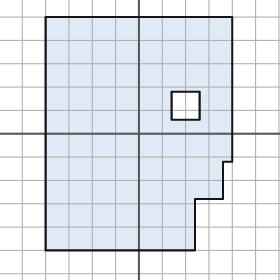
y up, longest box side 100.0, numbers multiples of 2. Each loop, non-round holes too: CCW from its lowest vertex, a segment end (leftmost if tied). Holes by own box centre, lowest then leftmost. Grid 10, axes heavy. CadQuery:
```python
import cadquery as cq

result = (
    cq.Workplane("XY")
    .moveTo(-40.0, -50.0)
    .lineTo(24.0, -50.0)
    .lineTo(24.0, -28.0)
    .lineTo(36.0, -28.0)
    .lineTo(36.0, -12.0)
    .lineTo(40.0, -12.0)
    .lineTo(40.0, 50.0)
    .lineTo(-40.0, 50.0)
    .close()
    .moveTo(14.0, 6.0)
    .lineTo(26.0, 6.0)
    .lineTo(26.0, 18.0)
    .lineTo(14.0, 18.0)
    .close()
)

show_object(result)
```